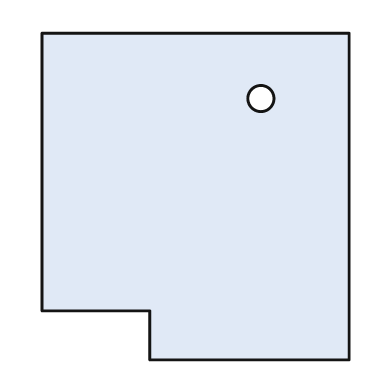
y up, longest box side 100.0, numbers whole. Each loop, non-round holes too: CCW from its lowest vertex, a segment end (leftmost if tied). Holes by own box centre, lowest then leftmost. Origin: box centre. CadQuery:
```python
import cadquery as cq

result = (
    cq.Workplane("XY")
    .moveTo(-14.0, -50.0)
    .lineTo(47.0, -50.0)
    .lineTo(47.0, 50.0)
    .lineTo(-47.0, 50.0)
    .lineTo(-47.0, -35.0)
    .lineTo(-14.0, -35.0)
    .close()
    .moveTo(20.0, 30.0)
    .circle(4.0)
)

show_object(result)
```